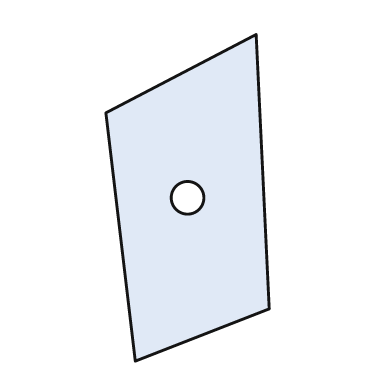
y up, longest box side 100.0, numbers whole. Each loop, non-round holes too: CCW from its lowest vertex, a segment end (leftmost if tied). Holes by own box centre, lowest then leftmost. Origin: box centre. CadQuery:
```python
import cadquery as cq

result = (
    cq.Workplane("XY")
    .moveTo(-16.0, -50.0)
    .lineTo(25.0, -34.0)
    .lineTo(21.0, 50.0)
    .lineTo(-25.0, 26.0)
    .close()
    .moveTo(0.0, 0.0)
    .circle(5.0)
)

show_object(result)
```